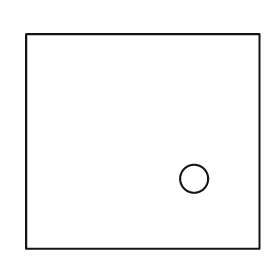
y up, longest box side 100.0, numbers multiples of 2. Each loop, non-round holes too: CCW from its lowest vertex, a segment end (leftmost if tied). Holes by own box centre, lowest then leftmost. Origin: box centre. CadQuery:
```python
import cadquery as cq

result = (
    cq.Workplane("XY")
    .moveTo(-50.0, -46.0)
    .lineTo(50.0, -46.0)
    .lineTo(50.0, 46.0)
    .lineTo(-50.0, 46.0)
    .close()
    .moveTo(22.0, -16.0)
    .circle(6.0)
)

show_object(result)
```